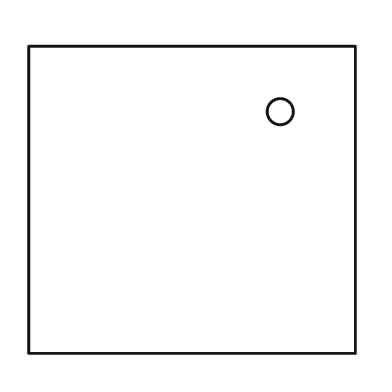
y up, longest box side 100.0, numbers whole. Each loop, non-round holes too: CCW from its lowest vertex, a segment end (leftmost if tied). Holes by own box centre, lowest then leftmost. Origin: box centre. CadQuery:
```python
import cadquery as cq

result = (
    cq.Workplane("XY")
    .moveTo(-50.0, -47.0)
    .lineTo(50.0, -47.0)
    .lineTo(50.0, 47.0)
    .lineTo(-50.0, 47.0)
    .close()
    .moveTo(27.0, 27.0)
    .circle(4.0)
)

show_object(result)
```